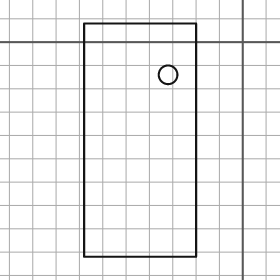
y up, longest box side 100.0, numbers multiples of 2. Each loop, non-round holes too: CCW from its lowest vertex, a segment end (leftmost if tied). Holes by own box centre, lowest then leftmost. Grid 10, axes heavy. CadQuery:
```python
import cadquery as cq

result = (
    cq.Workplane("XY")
    .moveTo(-68.0, -92.0)
    .lineTo(-20.0, -92.0)
    .lineTo(-20.0, 8.0)
    .lineTo(-68.0, 8.0)
    .close()
    .moveTo(-32.0, -14.0)
    .circle(4.0)
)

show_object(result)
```